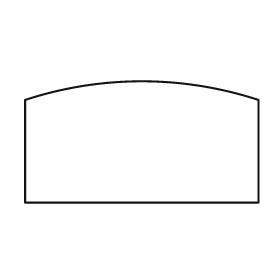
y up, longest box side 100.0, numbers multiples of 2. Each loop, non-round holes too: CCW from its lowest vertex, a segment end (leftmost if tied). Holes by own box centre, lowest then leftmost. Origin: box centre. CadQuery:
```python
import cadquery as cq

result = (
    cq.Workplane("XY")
    .moveTo(-50.0, -26.0)
    .lineTo(50.0, -26.0)
    .lineTo(50.0, 18.0)
    .threePointArc((0.0, 26.0), (-50.0, 18.0))
    .close()
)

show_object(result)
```